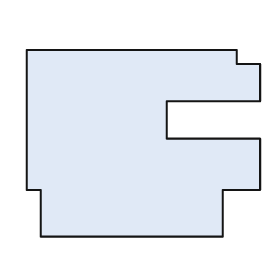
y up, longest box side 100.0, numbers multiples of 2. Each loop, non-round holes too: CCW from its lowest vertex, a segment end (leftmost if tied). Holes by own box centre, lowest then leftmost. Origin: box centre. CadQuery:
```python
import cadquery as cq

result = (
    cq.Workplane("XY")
    .moveTo(-44.0, -40.0)
    .lineTo(34.0, -40.0)
    .lineTo(34.0, -20.0)
    .lineTo(50.0, -20.0)
    .lineTo(50.0, 2.0)
    .lineTo(10.0, 2.0)
    .lineTo(10.0, 18.0)
    .lineTo(50.0, 18.0)
    .lineTo(50.0, 34.0)
    .lineTo(40.0, 34.0)
    .lineTo(40.0, 40.0)
    .lineTo(-50.0, 40.0)
    .lineTo(-50.0, -20.0)
    .lineTo(-44.0, -20.0)
    .close()
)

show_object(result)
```